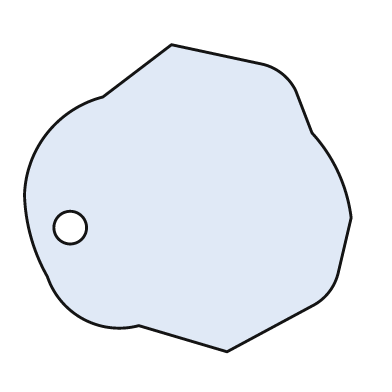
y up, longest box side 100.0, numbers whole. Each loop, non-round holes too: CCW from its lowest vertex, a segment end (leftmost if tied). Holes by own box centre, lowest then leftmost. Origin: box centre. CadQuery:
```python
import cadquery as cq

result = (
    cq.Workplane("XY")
    .moveTo(12.0, -47.0)
    .lineTo(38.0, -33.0)
    .threePointArc((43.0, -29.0), (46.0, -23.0))
    .lineTo(50.0, -6.0)
    .threePointArc((46.0, 8.0), (38.0, 20.0))
    .lineTo(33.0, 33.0)
    .threePointArc((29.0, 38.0), (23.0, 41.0))
    .lineTo(-5.0, 47.0)
    .lineTo(-26.0, 31.0)
    .threePointArc((-43.0, 20.0), (-50.0, 1.0))
    .threePointArc((-48.0, -12.0), (-43.0, -24.0))
    .threePointArc((-32.0, -37.0), (-15.0, -39.0))
    .close()
    .moveTo(-36.0, -9.0)
    .circle(5.0)
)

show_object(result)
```